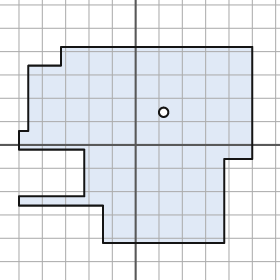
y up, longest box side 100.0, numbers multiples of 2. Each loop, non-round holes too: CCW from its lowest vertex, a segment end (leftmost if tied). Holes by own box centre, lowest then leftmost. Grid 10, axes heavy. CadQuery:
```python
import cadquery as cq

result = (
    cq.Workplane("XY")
    .moveTo(-14.0, -42.0)
    .lineTo(38.0, -42.0)
    .lineTo(38.0, -6.0)
    .lineTo(50.0, -6.0)
    .lineTo(50.0, 42.0)
    .lineTo(-32.0, 42.0)
    .lineTo(-32.0, 34.0)
    .lineTo(-46.0, 34.0)
    .lineTo(-46.0, 6.0)
    .lineTo(-50.0, 6.0)
    .lineTo(-50.0, -2.0)
    .lineTo(-22.0, -2.0)
    .lineTo(-22.0, -22.0)
    .lineTo(-50.0, -22.0)
    .lineTo(-50.0, -26.0)
    .lineTo(-14.0, -26.0)
    .close()
    .moveTo(12.0, 14.0)
    .circle(2.0)
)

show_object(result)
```